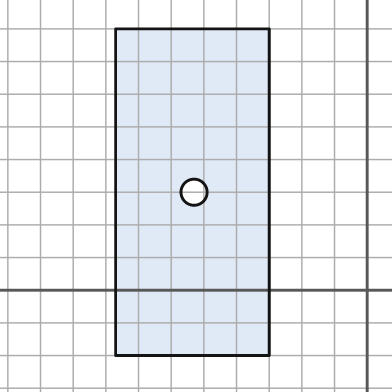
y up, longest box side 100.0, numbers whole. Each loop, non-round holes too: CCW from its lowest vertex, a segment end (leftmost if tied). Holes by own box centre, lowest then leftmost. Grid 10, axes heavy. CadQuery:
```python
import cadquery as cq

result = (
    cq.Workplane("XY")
    .moveTo(-77.0, -20.0)
    .lineTo(-30.0, -20.0)
    .lineTo(-30.0, 80.0)
    .lineTo(-77.0, 80.0)
    .close()
    .moveTo(-53.0, 30.0)
    .circle(4.0)
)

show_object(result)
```